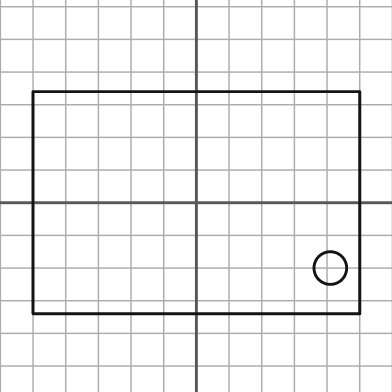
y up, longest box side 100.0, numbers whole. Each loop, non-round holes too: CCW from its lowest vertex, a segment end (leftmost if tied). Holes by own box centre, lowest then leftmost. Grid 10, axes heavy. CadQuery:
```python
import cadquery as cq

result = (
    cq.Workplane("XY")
    .moveTo(-50.0, -34.0)
    .lineTo(50.0, -34.0)
    .lineTo(50.0, 34.0)
    .lineTo(-50.0, 34.0)
    .close()
    .moveTo(41.0, -20.0)
    .circle(5.0)
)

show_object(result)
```